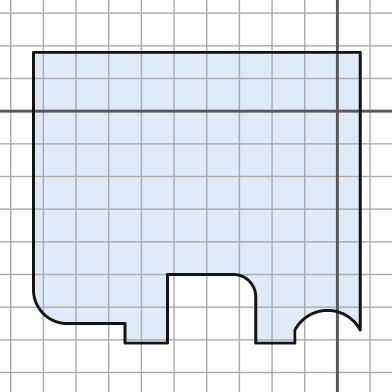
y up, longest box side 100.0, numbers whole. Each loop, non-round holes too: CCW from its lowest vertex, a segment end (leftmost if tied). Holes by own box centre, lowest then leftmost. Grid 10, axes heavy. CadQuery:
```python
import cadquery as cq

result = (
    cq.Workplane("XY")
    .moveTo(-65.0, -71.0)
    .lineTo(-52.0, -71.0)
    .lineTo(-52.0, -50.0)
    .lineTo(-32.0, -50.0)
    .threePointArc((-27.0, -52.0), (-25.0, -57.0))
    .lineTo(-25.0, -71.0)
    .lineTo(-13.0, -71.0)
    .lineTo(-13.0, -67.0)
    .threePointArc((-3.0, -61.0), (7.0, -67.0))
    .lineTo(7.0, 18.0)
    .lineTo(-93.0, 18.0)
    .lineTo(-93.0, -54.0)
    .threePointArc((-90.0, -62.0), (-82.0, -65.0))
    .lineTo(-65.0, -65.0)
    .close()
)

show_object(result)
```